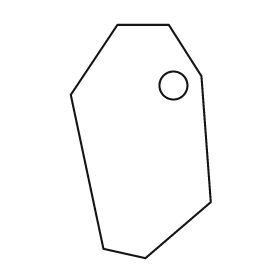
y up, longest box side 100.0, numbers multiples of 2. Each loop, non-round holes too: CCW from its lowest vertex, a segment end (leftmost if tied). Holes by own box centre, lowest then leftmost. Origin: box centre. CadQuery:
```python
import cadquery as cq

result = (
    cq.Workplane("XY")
    .moveTo(2.0, -50.0)
    .lineTo(30.0, -26.0)
    .lineTo(26.0, 28.0)
    .lineTo(12.0, 50.0)
    .lineTo(-10.0, 50.0)
    .lineTo(-30.0, 20.0)
    .lineTo(-16.0, -46.0)
    .close()
    .moveTo(14.0, 24.0)
    .circle(6.0)
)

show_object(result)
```